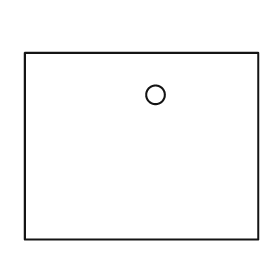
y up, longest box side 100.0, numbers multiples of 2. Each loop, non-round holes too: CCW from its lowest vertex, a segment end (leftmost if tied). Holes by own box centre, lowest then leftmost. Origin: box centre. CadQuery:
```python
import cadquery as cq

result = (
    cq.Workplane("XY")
    .moveTo(-50.0, -40.0)
    .lineTo(50.0, -40.0)
    .lineTo(50.0, 40.0)
    .lineTo(-50.0, 40.0)
    .close()
    .moveTo(6.0, 22.0)
    .circle(4.0)
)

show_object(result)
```